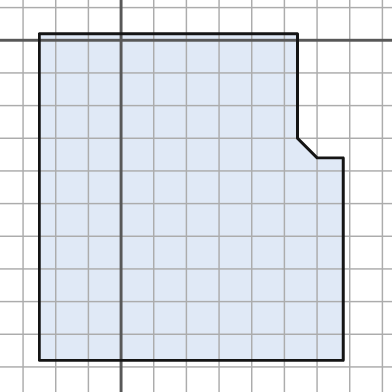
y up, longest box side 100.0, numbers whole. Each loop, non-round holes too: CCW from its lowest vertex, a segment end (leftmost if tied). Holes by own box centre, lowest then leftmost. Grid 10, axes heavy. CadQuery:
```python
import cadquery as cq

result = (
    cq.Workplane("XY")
    .moveTo(-25.0, -98.0)
    .lineTo(68.0, -98.0)
    .lineTo(68.0, -36.0)
    .lineTo(60.0, -36.0)
    .lineTo(54.0, -30.0)
    .lineTo(54.0, 2.0)
    .lineTo(-25.0, 2.0)
    .close()
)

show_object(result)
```